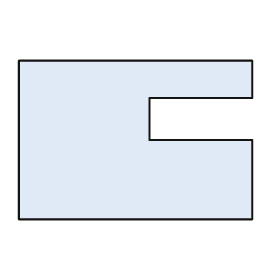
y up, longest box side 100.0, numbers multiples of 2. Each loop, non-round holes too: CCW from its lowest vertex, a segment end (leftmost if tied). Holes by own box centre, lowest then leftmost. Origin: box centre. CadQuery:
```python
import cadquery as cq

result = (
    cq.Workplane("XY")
    .moveTo(-50.0, -34.0)
    .lineTo(50.0, -34.0)
    .lineTo(50.0, 0.0)
    .lineTo(6.0, 0.0)
    .lineTo(6.0, 18.0)
    .lineTo(50.0, 18.0)
    .lineTo(50.0, 34.0)
    .lineTo(-50.0, 34.0)
    .close()
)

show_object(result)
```